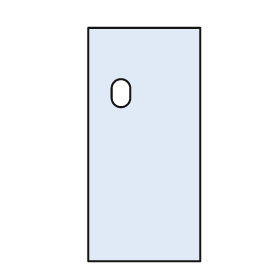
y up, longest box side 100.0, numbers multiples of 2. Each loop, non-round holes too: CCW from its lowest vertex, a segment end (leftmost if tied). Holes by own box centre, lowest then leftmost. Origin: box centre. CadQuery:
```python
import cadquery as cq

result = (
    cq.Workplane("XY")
    .moveTo(-24.0, -50.0)
    .lineTo(24.0, -50.0)
    .lineTo(24.0, 50.0)
    .lineTo(-24.0, 50.0)
    .close()
    .moveTo(-14.0, 20.0)
    .threePointArc((-10.0, 16.0), (-6.0, 20.0))
    .lineTo(-6.0, 24.0)
    .threePointArc((-10.0, 28.0), (-14.0, 24.0))
    .close()
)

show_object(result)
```